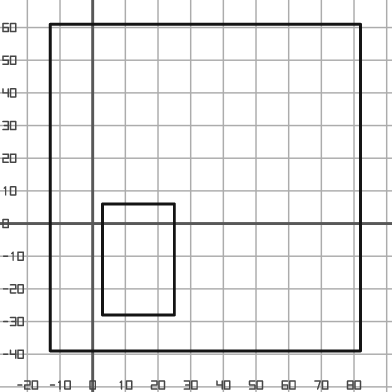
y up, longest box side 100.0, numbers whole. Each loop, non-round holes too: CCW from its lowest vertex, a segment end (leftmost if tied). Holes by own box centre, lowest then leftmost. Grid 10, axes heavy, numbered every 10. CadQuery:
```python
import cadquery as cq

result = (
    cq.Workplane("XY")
    .moveTo(-13.0, -39.0)
    .lineTo(82.0, -39.0)
    .lineTo(82.0, 61.0)
    .lineTo(-13.0, 61.0)
    .close()
    .moveTo(3.0, -28.0)
    .lineTo(25.0, -28.0)
    .lineTo(25.0, 6.0)
    .lineTo(3.0, 6.0)
    .close()
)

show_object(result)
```